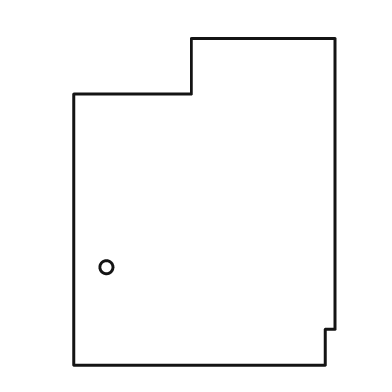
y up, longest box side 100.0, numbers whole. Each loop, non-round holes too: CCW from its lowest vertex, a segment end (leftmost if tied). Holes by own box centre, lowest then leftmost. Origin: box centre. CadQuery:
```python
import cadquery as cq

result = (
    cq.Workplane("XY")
    .moveTo(-40.0, -50.0)
    .lineTo(37.0, -50.0)
    .lineTo(37.0, -39.0)
    .lineTo(40.0, -39.0)
    .lineTo(40.0, 50.0)
    .lineTo(-4.0, 50.0)
    .lineTo(-4.0, 33.0)
    .lineTo(-40.0, 33.0)
    .close()
    .moveTo(-30.0, -20.0)
    .circle(2.0)
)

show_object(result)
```